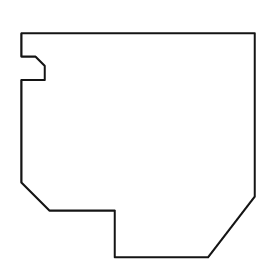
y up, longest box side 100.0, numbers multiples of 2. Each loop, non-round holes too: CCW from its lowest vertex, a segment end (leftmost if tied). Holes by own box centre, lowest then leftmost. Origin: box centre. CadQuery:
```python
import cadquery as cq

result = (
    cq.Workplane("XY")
    .moveTo(-10.0, -48.0)
    .lineTo(30.0, -48.0)
    .lineTo(50.0, -22.0)
    .lineTo(50.0, 48.0)
    .lineTo(-50.0, 48.0)
    .lineTo(-50.0, 38.0)
    .lineTo(-44.0, 38.0)
    .lineTo(-40.0, 34.0)
    .lineTo(-40.0, 28.0)
    .lineTo(-50.0, 28.0)
    .lineTo(-50.0, -16.0)
    .lineTo(-38.0, -28.0)
    .lineTo(-10.0, -28.0)
    .close()
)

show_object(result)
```